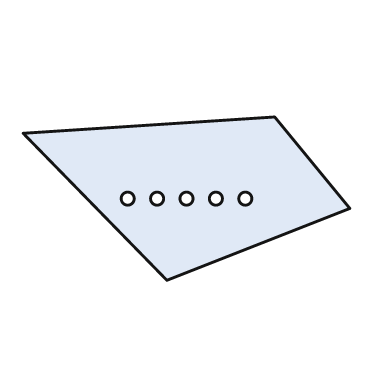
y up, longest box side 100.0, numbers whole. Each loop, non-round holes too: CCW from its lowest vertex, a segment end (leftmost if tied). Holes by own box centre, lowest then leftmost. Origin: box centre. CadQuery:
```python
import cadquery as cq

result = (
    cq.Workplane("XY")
    .moveTo(-6.0, -25.0)
    .lineTo(50.0, -3.0)
    .lineTo(27.0, 25.0)
    .lineTo(-50.0, 20.0)
    .close()
    .moveTo(-18.0, 0.0)
    .circle(2.0)
    .moveTo(-9.0, 0.0)
    .circle(2.0)
    .moveTo(0.0, 0.0)
    .circle(2.0)
    .moveTo(9.0, 0.0)
    .circle(2.0)
    .moveTo(18.0, 0.0)
    .circle(2.0)
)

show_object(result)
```